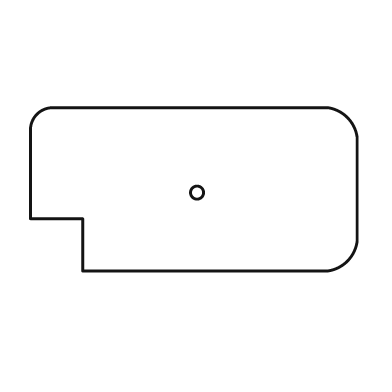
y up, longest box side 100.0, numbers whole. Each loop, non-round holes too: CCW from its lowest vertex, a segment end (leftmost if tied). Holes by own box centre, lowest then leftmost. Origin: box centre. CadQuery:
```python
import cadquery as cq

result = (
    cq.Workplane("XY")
    .moveTo(-34.0, -25.0)
    .lineTo(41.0, -25.0)
    .threePointArc((47.0, -22.0), (50.0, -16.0))
    .lineTo(50.0, 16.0)
    .threePointArc((47.0, 22.0), (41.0, 25.0))
    .lineTo(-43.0, 25.0)
    .threePointArc((-48.0, 23.0), (-50.0, 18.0))
    .lineTo(-50.0, -9.0)
    .lineTo(-34.0, -9.0)
    .close()
    .moveTo(1.0, -1.0)
    .circle(2.0)
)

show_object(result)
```